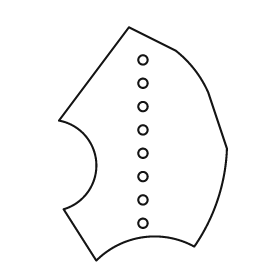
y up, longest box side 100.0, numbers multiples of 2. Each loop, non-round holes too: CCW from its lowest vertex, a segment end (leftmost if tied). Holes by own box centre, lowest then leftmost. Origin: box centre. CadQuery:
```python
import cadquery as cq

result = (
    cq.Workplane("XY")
    .moveTo(-20.0, -50.0)
    .threePointArc((0.0, -40.0), (22.0, -44.0))
    .threePointArc((32.0, -24.0), (36.0, -2.0))
    .lineTo(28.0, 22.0)
    .threePointArc((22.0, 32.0), (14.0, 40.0))
    .lineTo(-6.0, 50.0)
    .lineTo(-36.0, 10.0)
    .threePointArc((-20.0, -8.0), (-34.0, -28.0))
    .close()
    .moveTo(0.0, -34.0)
    .circle(2.0)
    .moveTo(0.0, -24.0)
    .circle(2.0)
    .moveTo(0.0, -14.0)
    .circle(2.0)
    .moveTo(0.0, -4.0)
    .circle(2.0)
    .moveTo(0.0, 6.0)
    .circle(2.0)
    .moveTo(0.0, 16.0)
    .circle(2.0)
    .moveTo(0.0, 26.0)
    .circle(2.0)
    .moveTo(0.0, 36.0)
    .circle(2.0)
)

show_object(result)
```